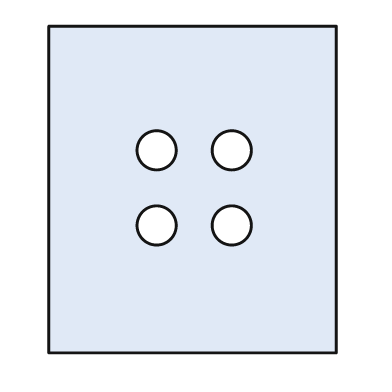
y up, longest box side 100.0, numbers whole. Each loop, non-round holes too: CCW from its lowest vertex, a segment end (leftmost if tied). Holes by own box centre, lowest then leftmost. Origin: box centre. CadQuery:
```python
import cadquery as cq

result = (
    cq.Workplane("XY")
    .moveTo(-44.0, -50.0)
    .lineTo(44.0, -50.0)
    .lineTo(44.0, 50.0)
    .lineTo(-44.0, 50.0)
    .close()
    .moveTo(-11.0, -11.0)
    .circle(6.0)
    .moveTo(12.0, -11.0)
    .circle(6.0)
    .moveTo(-11.0, 12.0)
    .circle(6.0)
    .moveTo(12.0, 12.0)
    .circle(6.0)
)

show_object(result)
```